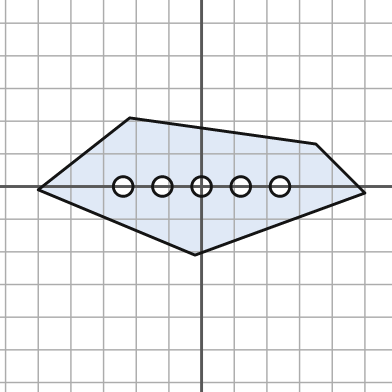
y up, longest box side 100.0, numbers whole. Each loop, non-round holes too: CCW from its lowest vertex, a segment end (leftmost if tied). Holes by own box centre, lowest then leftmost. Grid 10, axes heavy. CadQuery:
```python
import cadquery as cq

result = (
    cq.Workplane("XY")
    .moveTo(-2.0, -21.0)
    .lineTo(50.0, -2.0)
    .lineTo(35.0, 13.0)
    .lineTo(-22.0, 21.0)
    .lineTo(-50.0, -1.0)
    .close()
    .moveTo(-24.0, 0.0)
    .circle(3.0)
    .moveTo(-12.0, 0.0)
    .circle(3.0)
    .moveTo(0.0, 0.0)
    .circle(3.0)
    .moveTo(12.0, 0.0)
    .circle(3.0)
    .moveTo(24.0, 0.0)
    .circle(3.0)
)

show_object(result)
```